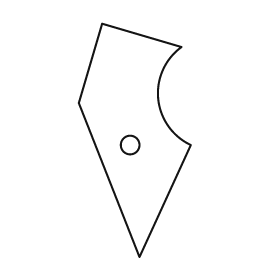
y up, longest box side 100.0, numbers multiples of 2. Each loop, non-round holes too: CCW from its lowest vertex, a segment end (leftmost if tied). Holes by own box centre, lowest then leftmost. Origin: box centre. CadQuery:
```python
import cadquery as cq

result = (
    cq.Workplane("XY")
    .moveTo(2.0, -50.0)
    .lineTo(24.0, -2.0)
    .threePointArc((10.0, 18.0), (20.0, 40.0))
    .lineTo(-14.0, 50.0)
    .lineTo(-24.0, 16.0)
    .close()
    .moveTo(-2.0, -2.0)
    .circle(4.0)
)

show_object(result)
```